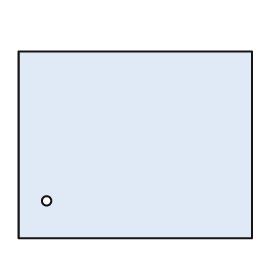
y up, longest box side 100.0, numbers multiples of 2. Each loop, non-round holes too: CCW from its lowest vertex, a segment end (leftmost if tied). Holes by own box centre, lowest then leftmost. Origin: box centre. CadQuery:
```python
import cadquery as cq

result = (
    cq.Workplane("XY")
    .moveTo(-50.0, -40.0)
    .lineTo(50.0, -40.0)
    .lineTo(50.0, 40.0)
    .lineTo(-50.0, 40.0)
    .close()
    .moveTo(-38.0, -24.0)
    .circle(2.0)
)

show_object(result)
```